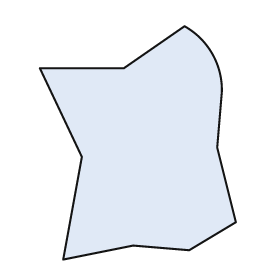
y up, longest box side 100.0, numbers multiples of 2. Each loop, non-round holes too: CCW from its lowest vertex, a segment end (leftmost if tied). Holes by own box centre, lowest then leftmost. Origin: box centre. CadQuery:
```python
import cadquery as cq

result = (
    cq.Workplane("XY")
    .moveTo(-32.0, -50.0)
    .lineTo(-2.0, -44.0)
    .lineTo(22.0, -46.0)
    .lineTo(42.0, -34.0)
    .lineTo(34.0, -2.0)
    .lineTo(36.0, 22.0)
    .threePointArc((32.0, 38.0), (20.0, 50.0))
    .lineTo(-6.0, 32.0)
    .lineTo(-42.0, 32.0)
    .lineTo(-24.0, -6.0)
    .close()
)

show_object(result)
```